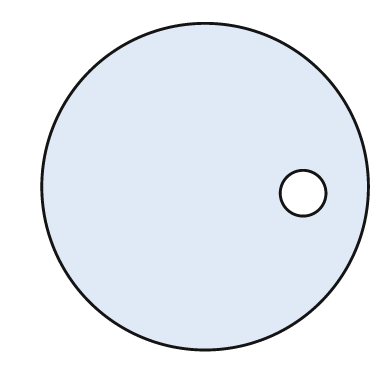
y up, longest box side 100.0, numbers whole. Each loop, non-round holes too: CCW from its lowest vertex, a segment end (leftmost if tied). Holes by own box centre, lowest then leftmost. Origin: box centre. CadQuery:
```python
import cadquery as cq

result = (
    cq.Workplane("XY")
    .moveTo(0.0, 0.0)
    .circle(50.0)
    .moveTo(30.0, -2.0)
    .circle(7.0)
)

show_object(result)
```